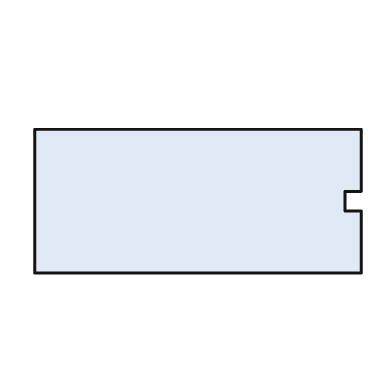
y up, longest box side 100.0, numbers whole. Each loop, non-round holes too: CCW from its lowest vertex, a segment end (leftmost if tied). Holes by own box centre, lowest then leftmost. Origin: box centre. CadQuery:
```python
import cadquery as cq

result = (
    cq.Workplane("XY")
    .moveTo(-50.0, -22.0)
    .lineTo(50.0, -22.0)
    .lineTo(50.0, -3.0)
    .lineTo(45.0, -3.0)
    .lineTo(45.0, 3.0)
    .lineTo(50.0, 3.0)
    .lineTo(50.0, 22.0)
    .lineTo(-50.0, 22.0)
    .close()
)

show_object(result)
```